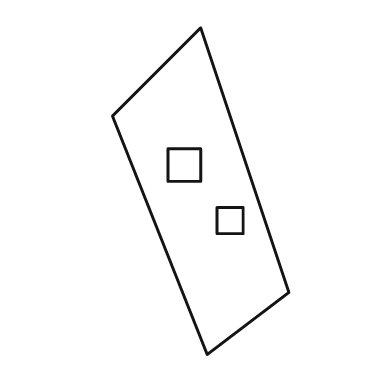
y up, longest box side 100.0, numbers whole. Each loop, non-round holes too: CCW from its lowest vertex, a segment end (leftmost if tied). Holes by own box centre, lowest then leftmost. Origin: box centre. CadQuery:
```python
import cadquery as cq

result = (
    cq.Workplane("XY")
    .moveTo(2.0, -50.0)
    .lineTo(27.0, -31.0)
    .lineTo(0.0, 50.0)
    .lineTo(-27.0, 23.0)
    .close()
    .moveTo(5.0, -13.0)
    .lineTo(13.0, -13.0)
    .lineTo(13.0, -5.0)
    .lineTo(5.0, -5.0)
    .close()
    .moveTo(-10.0, 3.0)
    .lineTo(0.0, 3.0)
    .lineTo(0.0, 13.0)
    .lineTo(-10.0, 13.0)
    .close()
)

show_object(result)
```